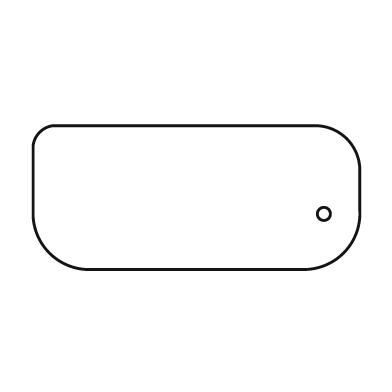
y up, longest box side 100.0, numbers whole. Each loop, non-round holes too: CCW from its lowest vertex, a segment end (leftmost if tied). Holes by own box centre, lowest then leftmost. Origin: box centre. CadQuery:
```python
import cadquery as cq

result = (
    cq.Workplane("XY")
    .moveTo(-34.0, -22.0)
    .lineTo(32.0, -22.0)
    .threePointArc((45.0, -17.0), (50.0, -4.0))
    .lineTo(50.0, 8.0)
    .threePointArc((46.0, 18.0), (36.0, 22.0))
    .lineTo(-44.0, 22.0)
    .threePointArc((-48.0, 20.0), (-50.0, 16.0))
    .lineTo(-50.0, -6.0)
    .threePointArc((-45.0, -17.0), (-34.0, -22.0))
    .close()
    .moveTo(39.0, -5.0)
    .circle(2.0)
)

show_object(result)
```